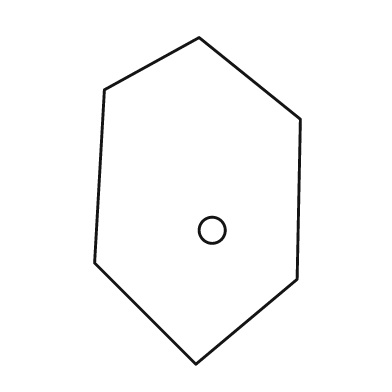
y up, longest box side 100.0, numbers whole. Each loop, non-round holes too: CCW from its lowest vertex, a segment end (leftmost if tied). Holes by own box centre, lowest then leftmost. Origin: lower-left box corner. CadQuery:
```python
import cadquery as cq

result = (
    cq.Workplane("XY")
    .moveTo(31.0, 0.0)
    .lineTo(62.0, 26.0)
    .lineTo(63.0, 75.0)
    .lineTo(32.0, 100.0)
    .lineTo(3.0, 84.0)
    .lineTo(0.0, 31.0)
    .close()
    .moveTo(36.0, 41.0)
    .circle(4.0)
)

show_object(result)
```